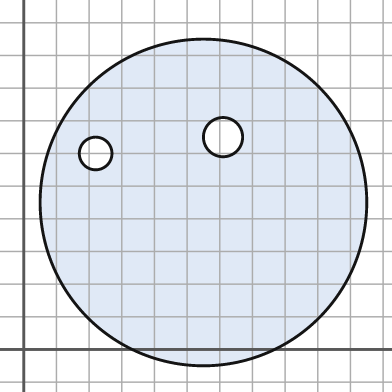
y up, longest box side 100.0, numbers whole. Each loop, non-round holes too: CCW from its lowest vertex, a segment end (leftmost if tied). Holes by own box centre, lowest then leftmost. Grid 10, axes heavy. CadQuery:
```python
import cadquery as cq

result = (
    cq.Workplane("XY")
    .moveTo(55.0, 45.0)
    .circle(50.0)
    .moveTo(22.0, 60.0)
    .circle(5.0)
    .moveTo(61.0, 65.0)
    .circle(6.0)
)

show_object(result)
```